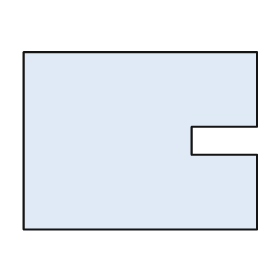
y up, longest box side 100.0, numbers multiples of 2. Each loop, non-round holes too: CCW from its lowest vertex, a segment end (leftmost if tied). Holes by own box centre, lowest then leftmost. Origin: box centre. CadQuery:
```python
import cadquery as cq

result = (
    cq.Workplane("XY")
    .moveTo(-50.0, -38.0)
    .lineTo(50.0, -38.0)
    .lineTo(50.0, -6.0)
    .lineTo(22.0, -6.0)
    .lineTo(22.0, 6.0)
    .lineTo(50.0, 6.0)
    .lineTo(50.0, 38.0)
    .lineTo(-50.0, 38.0)
    .close()
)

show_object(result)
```